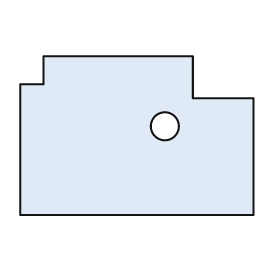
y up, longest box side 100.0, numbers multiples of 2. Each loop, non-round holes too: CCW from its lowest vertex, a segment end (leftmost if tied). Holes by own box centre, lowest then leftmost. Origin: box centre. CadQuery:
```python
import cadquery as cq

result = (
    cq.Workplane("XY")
    .moveTo(-50.0, -34.0)
    .lineTo(50.0, -34.0)
    .lineTo(50.0, 16.0)
    .lineTo(24.0, 16.0)
    .lineTo(24.0, 34.0)
    .lineTo(-40.0, 34.0)
    .lineTo(-40.0, 22.0)
    .lineTo(-50.0, 22.0)
    .close()
    .moveTo(12.0, 4.0)
    .circle(6.0)
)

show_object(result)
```